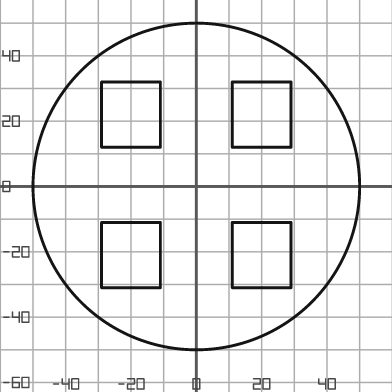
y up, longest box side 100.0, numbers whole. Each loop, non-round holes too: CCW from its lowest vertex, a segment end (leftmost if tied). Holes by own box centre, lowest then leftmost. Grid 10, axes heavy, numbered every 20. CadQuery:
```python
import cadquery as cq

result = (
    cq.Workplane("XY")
    .moveTo(0.0, 0.0)
    .circle(50.0)
    .moveTo(-29.0, -31.0)
    .lineTo(-11.0, -31.0)
    .lineTo(-11.0, -11.0)
    .lineTo(-29.0, -11.0)
    .close()
    .moveTo(11.0, -31.0)
    .lineTo(29.0, -31.0)
    .lineTo(29.0, -11.0)
    .lineTo(11.0, -11.0)
    .close()
    .moveTo(-29.0, 12.0)
    .lineTo(-11.0, 12.0)
    .lineTo(-11.0, 32.0)
    .lineTo(-29.0, 32.0)
    .close()
    .moveTo(11.0, 12.0)
    .lineTo(29.0, 12.0)
    .lineTo(29.0, 32.0)
    .lineTo(11.0, 32.0)
    .close()
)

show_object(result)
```